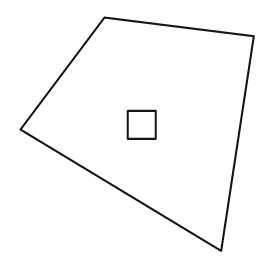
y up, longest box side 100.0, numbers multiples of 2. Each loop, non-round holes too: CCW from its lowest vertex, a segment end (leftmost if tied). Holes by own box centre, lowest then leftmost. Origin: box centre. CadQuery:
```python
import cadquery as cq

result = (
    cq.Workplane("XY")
    .moveTo(36.0, -50.0)
    .lineTo(50.0, 42.0)
    .lineTo(-14.0, 50.0)
    .lineTo(-50.0, 2.0)
    .close()
    .moveTo(-4.0, -2.0)
    .lineTo(8.0, -2.0)
    .lineTo(8.0, 10.0)
    .lineTo(-4.0, 10.0)
    .close()
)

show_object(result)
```